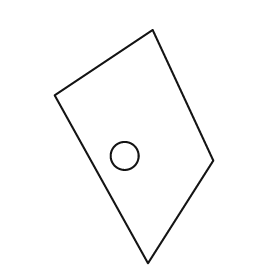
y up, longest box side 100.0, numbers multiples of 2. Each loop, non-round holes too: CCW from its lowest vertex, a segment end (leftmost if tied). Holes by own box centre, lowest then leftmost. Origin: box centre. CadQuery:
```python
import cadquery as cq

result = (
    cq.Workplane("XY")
    .moveTo(6.0, -50.0)
    .lineTo(34.0, -6.0)
    .lineTo(8.0, 50.0)
    .lineTo(-34.0, 22.0)
    .close()
    .moveTo(-4.0, -4.0)
    .circle(6.0)
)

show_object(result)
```